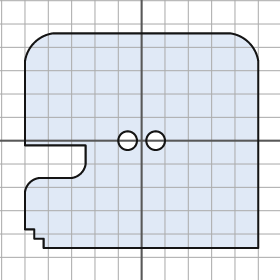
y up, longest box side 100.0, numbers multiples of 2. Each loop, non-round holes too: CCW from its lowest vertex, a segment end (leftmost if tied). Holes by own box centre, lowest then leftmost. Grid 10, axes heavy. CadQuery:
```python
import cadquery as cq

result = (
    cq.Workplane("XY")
    .moveTo(-42.0, -46.0)
    .lineTo(50.0, -46.0)
    .lineTo(50.0, 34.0)
    .threePointArc((46.0, 42.0), (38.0, 46.0))
    .lineTo(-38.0, 46.0)
    .threePointArc((-46.0, 42.0), (-50.0, 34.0))
    .lineTo(-50.0, -2.0)
    .lineTo(-24.0, -2.0)
    .lineTo(-24.0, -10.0)
    .threePointArc((-26.0, -14.0), (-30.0, -16.0))
    .lineTo(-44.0, -16.0)
    .threePointArc((-48.0, -18.0), (-50.0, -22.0))
    .lineTo(-50.0, -38.0)
    .lineTo(-46.0, -38.0)
    .lineTo(-46.0, -42.0)
    .lineTo(-42.0, -42.0)
    .close()
    .moveTo(-6.0, 0.0)
    .circle(4.0)
    .moveTo(6.0, 0.0)
    .circle(4.0)
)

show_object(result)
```